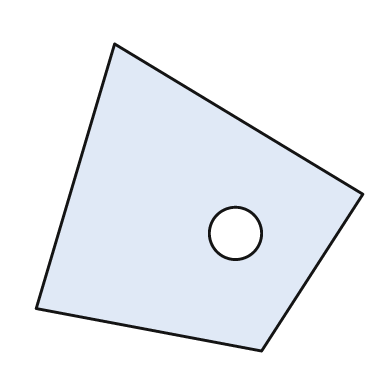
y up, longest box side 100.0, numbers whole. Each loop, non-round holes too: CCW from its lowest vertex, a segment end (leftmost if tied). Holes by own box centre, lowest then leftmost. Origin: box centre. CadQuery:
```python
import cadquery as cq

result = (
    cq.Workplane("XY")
    .moveTo(19.0, -47.0)
    .lineTo(50.0, 1.0)
    .lineTo(-26.0, 47.0)
    .lineTo(-50.0, -34.0)
    .close()
    .moveTo(11.0, -11.0)
    .circle(8.0)
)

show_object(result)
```